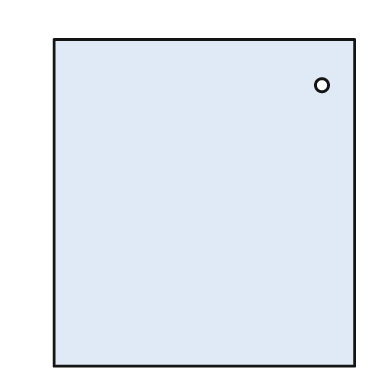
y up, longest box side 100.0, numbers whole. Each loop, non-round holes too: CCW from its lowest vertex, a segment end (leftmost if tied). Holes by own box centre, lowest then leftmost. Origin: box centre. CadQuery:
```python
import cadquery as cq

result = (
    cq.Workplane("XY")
    .moveTo(-46.0, -50.0)
    .lineTo(46.0, -50.0)
    .lineTo(46.0, 50.0)
    .lineTo(-46.0, 50.0)
    .close()
    .moveTo(36.0, 36.0)
    .circle(2.0)
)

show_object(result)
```